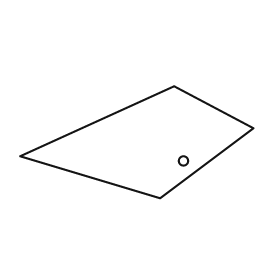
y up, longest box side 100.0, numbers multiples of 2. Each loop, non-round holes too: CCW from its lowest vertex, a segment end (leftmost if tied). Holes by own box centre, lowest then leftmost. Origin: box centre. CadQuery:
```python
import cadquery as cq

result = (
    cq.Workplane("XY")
    .moveTo(10.0, -24.0)
    .lineTo(50.0, 6.0)
    .lineTo(16.0, 24.0)
    .lineTo(-50.0, -6.0)
    .close()
    .moveTo(20.0, -8.0)
    .circle(2.0)
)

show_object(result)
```